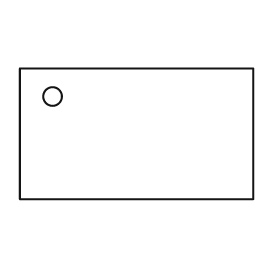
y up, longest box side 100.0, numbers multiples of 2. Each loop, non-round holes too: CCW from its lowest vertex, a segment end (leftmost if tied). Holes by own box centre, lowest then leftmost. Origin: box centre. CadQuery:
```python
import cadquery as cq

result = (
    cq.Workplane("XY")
    .moveTo(-50.0, -28.0)
    .lineTo(50.0, -28.0)
    .lineTo(50.0, 28.0)
    .lineTo(-50.0, 28.0)
    .close()
    .moveTo(-36.0, 16.0)
    .circle(4.0)
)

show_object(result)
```